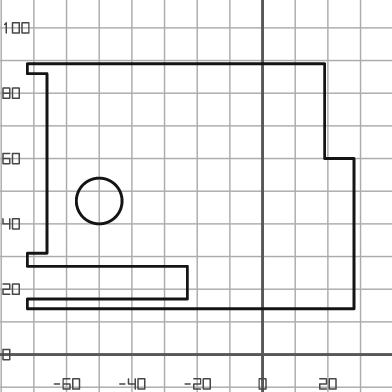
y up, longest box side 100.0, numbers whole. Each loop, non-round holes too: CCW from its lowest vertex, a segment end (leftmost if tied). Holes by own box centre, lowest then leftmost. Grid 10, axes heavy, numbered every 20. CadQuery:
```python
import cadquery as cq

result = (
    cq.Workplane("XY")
    .moveTo(-72.0, 14.0)
    .lineTo(28.0, 14.0)
    .lineTo(28.0, 60.0)
    .lineTo(19.0, 60.0)
    .lineTo(19.0, 89.0)
    .lineTo(-72.0, 89.0)
    .lineTo(-72.0, 86.0)
    .lineTo(-66.0, 86.0)
    .lineTo(-66.0, 31.0)
    .lineTo(-72.0, 31.0)
    .lineTo(-72.0, 27.0)
    .lineTo(-23.0, 27.0)
    .lineTo(-23.0, 17.0)
    .lineTo(-72.0, 17.0)
    .close()
    .moveTo(-50.0, 47.0)
    .circle(7.0)
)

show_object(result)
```